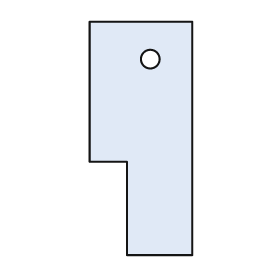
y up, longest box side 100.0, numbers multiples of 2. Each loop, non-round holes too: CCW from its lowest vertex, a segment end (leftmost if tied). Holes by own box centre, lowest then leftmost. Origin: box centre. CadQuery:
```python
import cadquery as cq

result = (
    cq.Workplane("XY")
    .moveTo(-6.0, -50.0)
    .lineTo(22.0, -50.0)
    .lineTo(22.0, 50.0)
    .lineTo(-22.0, 50.0)
    .lineTo(-22.0, -10.0)
    .lineTo(-6.0, -10.0)
    .close()
    .moveTo(4.0, 34.0)
    .circle(4.0)
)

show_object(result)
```